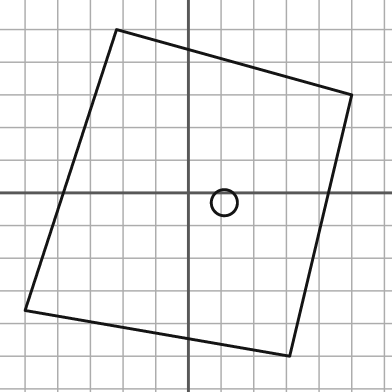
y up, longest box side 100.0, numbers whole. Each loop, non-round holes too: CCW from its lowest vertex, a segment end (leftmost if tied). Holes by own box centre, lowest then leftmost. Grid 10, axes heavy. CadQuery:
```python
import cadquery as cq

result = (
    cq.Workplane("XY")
    .moveTo(31.0, -50.0)
    .lineTo(50.0, 30.0)
    .lineTo(-22.0, 50.0)
    .lineTo(-50.0, -36.0)
    .close()
    .moveTo(11.0, -3.0)
    .circle(4.0)
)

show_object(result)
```